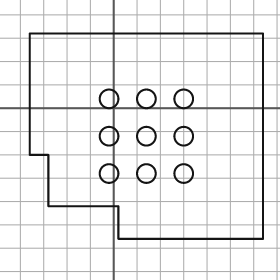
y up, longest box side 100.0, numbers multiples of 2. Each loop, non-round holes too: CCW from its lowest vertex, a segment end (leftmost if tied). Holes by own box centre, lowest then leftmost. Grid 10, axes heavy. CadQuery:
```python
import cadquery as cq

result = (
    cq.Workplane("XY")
    .moveTo(2.0, -56.0)
    .lineTo(64.0, -56.0)
    .lineTo(64.0, 32.0)
    .lineTo(-36.0, 32.0)
    .lineTo(-36.0, -20.0)
    .lineTo(-28.0, -20.0)
    .lineTo(-28.0, -42.0)
    .lineTo(2.0, -42.0)
    .close()
    .moveTo(-2.0, -28.0)
    .circle(4.0)
    .moveTo(14.0, -28.0)
    .circle(4.0)
    .moveTo(30.0, -28.0)
    .circle(4.0)
    .moveTo(-2.0, -12.0)
    .circle(4.0)
    .moveTo(14.0, -12.0)
    .circle(4.0)
    .moveTo(30.0, -12.0)
    .circle(4.0)
    .moveTo(-2.0, 4.0)
    .circle(4.0)
    .moveTo(14.0, 4.0)
    .circle(4.0)
    .moveTo(30.0, 4.0)
    .circle(4.0)
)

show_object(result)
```